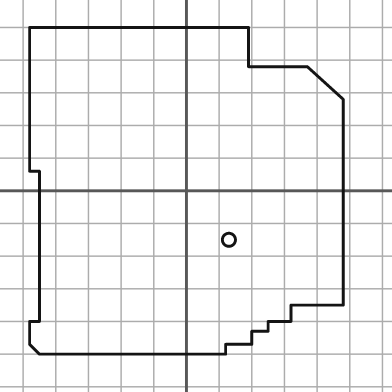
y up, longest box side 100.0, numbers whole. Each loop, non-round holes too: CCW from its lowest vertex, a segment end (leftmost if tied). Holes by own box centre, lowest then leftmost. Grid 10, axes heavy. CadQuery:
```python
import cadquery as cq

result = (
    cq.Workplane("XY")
    .moveTo(-45.0, -50.0)
    .lineTo(12.0, -50.0)
    .lineTo(12.0, -47.0)
    .lineTo(20.0, -47.0)
    .lineTo(20.0, -43.0)
    .lineTo(25.0, -43.0)
    .lineTo(25.0, -40.0)
    .lineTo(32.0, -40.0)
    .lineTo(32.0, -35.0)
    .lineTo(48.0, -35.0)
    .lineTo(48.0, 28.0)
    .lineTo(37.0, 38.0)
    .lineTo(19.0, 38.0)
    .lineTo(19.0, 50.0)
    .lineTo(-48.0, 50.0)
    .lineTo(-48.0, 6.0)
    .lineTo(-45.0, 6.0)
    .lineTo(-45.0, -40.0)
    .lineTo(-48.0, -40.0)
    .lineTo(-48.0, -47.0)
    .close()
    .moveTo(13.0, -15.0)
    .circle(2.0)
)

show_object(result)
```